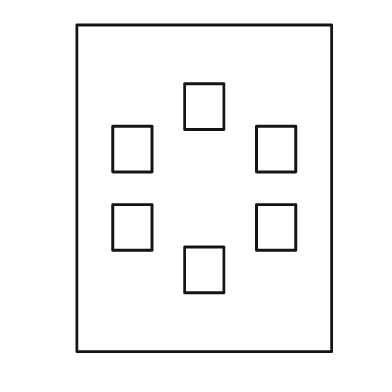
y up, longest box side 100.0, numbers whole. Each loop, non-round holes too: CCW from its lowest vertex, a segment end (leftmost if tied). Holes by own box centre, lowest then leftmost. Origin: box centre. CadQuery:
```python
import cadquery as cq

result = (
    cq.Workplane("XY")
    .moveTo(-39.0, -50.0)
    .lineTo(39.0, -50.0)
    .lineTo(39.0, 50.0)
    .lineTo(-39.0, 50.0)
    .close()
    .moveTo(-6.0, -32.0)
    .lineTo(6.0, -32.0)
    .lineTo(6.0, -18.0)
    .lineTo(-6.0, -18.0)
    .close()
    .moveTo(-28.0, -19.0)
    .lineTo(-16.0, -19.0)
    .lineTo(-16.0, -5.0)
    .lineTo(-28.0, -5.0)
    .close()
    .moveTo(16.0, -19.0)
    .lineTo(28.0, -19.0)
    .lineTo(28.0, -5.0)
    .lineTo(16.0, -5.0)
    .close()
    .moveTo(-28.0, 5.0)
    .lineTo(-16.0, 5.0)
    .lineTo(-16.0, 19.0)
    .lineTo(-28.0, 19.0)
    .close()
    .moveTo(16.0, 5.0)
    .lineTo(28.0, 5.0)
    .lineTo(28.0, 19.0)
    .lineTo(16.0, 19.0)
    .close()
    .moveTo(-6.0, 18.0)
    .lineTo(6.0, 18.0)
    .lineTo(6.0, 32.0)
    .lineTo(-6.0, 32.0)
    .close()
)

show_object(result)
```